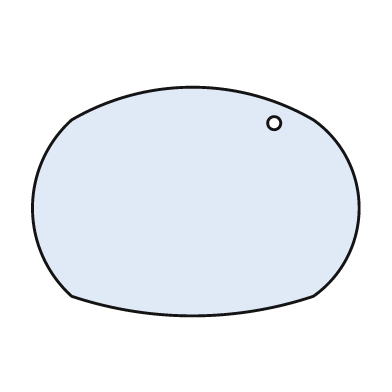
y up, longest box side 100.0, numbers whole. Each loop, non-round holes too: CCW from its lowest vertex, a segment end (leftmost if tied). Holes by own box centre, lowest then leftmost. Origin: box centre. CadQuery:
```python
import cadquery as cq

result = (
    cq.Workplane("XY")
    .moveTo(-38.0, -29.0)
    .threePointArc((-1.0, -35.0), (36.0, -29.0))
    .threePointArc((50.0, -2.0), (36.0, 25.0))
    .threePointArc((-1.0, 35.0), (-38.0, 25.0))
    .threePointArc((-50.0, -2.0), (-38.0, -29.0))
    .close()
    .moveTo(24.0, 24.0)
    .circle(2.0)
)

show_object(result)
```